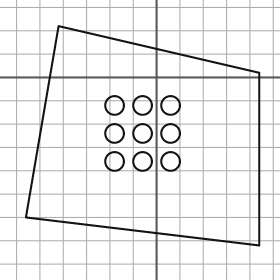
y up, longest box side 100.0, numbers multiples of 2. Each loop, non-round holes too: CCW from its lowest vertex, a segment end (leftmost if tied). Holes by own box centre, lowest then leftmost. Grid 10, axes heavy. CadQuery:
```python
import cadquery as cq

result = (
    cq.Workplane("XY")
    .moveTo(44.0, -72.0)
    .lineTo(44.0, 2.0)
    .lineTo(-42.0, 22.0)
    .lineTo(-56.0, -60.0)
    .close()
    .moveTo(-18.0, -36.0)
    .circle(4.0)
    .moveTo(-6.0, -36.0)
    .circle(4.0)
    .moveTo(6.0, -36.0)
    .circle(4.0)
    .moveTo(-18.0, -24.0)
    .circle(4.0)
    .moveTo(-6.0, -24.0)
    .circle(4.0)
    .moveTo(6.0, -24.0)
    .circle(4.0)
    .moveTo(-18.0, -12.0)
    .circle(4.0)
    .moveTo(-6.0, -12.0)
    .circle(4.0)
    .moveTo(6.0, -12.0)
    .circle(4.0)
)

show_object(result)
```